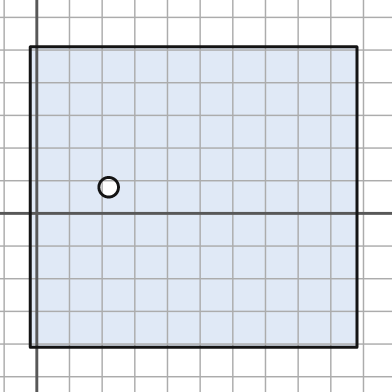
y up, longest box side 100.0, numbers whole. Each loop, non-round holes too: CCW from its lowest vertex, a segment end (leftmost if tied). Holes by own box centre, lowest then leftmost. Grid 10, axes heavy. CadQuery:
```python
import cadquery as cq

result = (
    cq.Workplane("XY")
    .moveTo(-2.0, -41.0)
    .lineTo(98.0, -41.0)
    .lineTo(98.0, 51.0)
    .lineTo(-2.0, 51.0)
    .close()
    .moveTo(22.0, 8.0)
    .circle(3.0)
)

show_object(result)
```